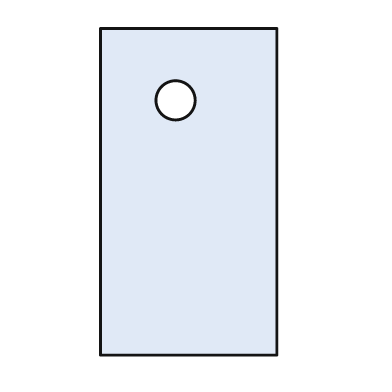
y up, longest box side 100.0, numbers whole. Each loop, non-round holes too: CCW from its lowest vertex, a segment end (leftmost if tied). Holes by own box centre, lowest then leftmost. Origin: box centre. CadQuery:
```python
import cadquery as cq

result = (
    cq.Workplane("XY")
    .moveTo(-27.0, -50.0)
    .lineTo(27.0, -50.0)
    .lineTo(27.0, 50.0)
    .lineTo(-27.0, 50.0)
    .close()
    .moveTo(-4.0, 28.0)
    .circle(6.0)
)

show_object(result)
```